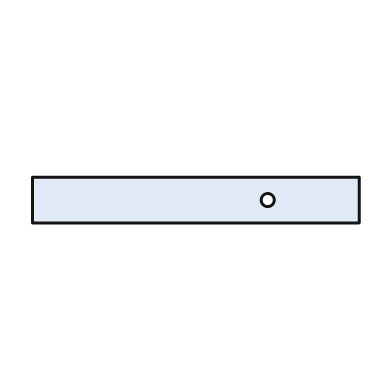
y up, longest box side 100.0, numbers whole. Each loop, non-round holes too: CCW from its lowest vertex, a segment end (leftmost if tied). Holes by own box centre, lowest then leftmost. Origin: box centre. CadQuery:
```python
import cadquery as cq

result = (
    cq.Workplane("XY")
    .moveTo(-50.0, -7.0)
    .lineTo(50.0, -7.0)
    .lineTo(50.0, 7.0)
    .lineTo(-50.0, 7.0)
    .close()
    .moveTo(22.0, 0.0)
    .circle(2.0)
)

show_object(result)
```